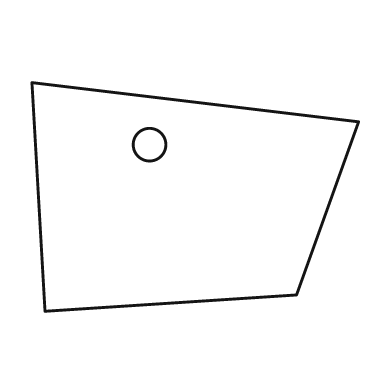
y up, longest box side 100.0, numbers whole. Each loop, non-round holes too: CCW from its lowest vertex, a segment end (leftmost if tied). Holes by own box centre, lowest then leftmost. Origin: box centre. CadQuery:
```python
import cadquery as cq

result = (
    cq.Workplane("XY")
    .moveTo(-46.0, -35.0)
    .lineTo(31.0, -30.0)
    .lineTo(50.0, 23.0)
    .lineTo(-50.0, 35.0)
    .close()
    .moveTo(-14.0, 16.0)
    .circle(5.0)
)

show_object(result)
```